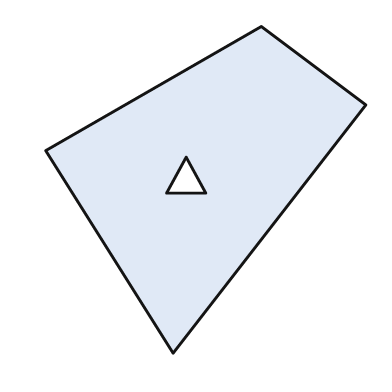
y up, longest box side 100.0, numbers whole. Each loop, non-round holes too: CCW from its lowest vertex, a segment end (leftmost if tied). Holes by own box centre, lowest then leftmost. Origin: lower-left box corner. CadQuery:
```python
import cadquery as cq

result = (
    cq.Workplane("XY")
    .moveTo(39.0, 0.0)
    .lineTo(98.0, 76.0)
    .lineTo(66.0, 100.0)
    .lineTo(0.0, 62.0)
    .close()
    .moveTo(37.0, 49.0)
    .lineTo(49.0, 49.0)
    .lineTo(43.0, 60.0)
    .close()
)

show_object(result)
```